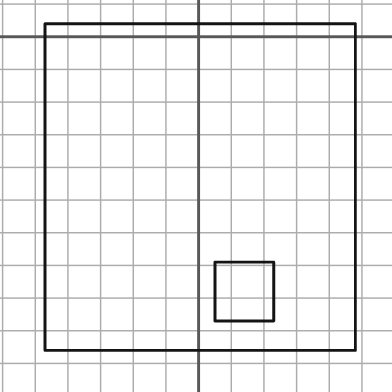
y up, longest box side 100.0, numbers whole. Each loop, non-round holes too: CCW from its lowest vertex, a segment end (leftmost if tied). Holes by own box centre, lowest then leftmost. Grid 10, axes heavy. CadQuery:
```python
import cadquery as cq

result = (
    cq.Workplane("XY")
    .moveTo(-47.0, -96.0)
    .lineTo(48.0, -96.0)
    .lineTo(48.0, 4.0)
    .lineTo(-47.0, 4.0)
    .close()
    .moveTo(5.0, -87.0)
    .lineTo(23.0, -87.0)
    .lineTo(23.0, -69.0)
    .lineTo(5.0, -69.0)
    .close()
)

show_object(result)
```